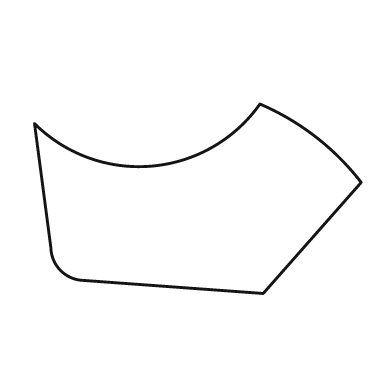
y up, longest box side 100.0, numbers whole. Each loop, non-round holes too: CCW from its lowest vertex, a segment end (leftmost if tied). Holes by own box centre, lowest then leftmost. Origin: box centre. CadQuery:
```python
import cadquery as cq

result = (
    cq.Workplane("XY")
    .moveTo(20.0, -29.0)
    .lineTo(50.0, 5.0)
    .threePointArc((36.0, 19.0), (19.0, 29.0))
    .threePointArc((-14.0, 10.0), (-50.0, 23.0))
    .lineTo(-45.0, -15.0)
    .threePointArc((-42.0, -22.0), (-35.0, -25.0))
    .close()
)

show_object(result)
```